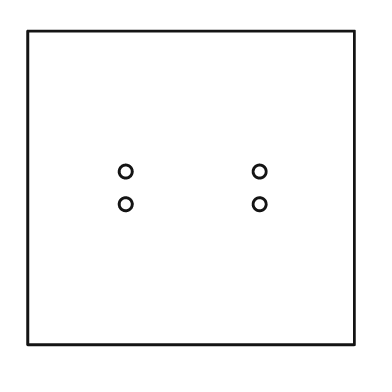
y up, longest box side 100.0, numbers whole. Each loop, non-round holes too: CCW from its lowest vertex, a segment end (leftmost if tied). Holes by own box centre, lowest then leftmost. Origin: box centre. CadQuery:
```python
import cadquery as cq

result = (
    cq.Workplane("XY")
    .moveTo(-50.0, -48.0)
    .lineTo(50.0, -48.0)
    .lineTo(50.0, 48.0)
    .lineTo(-50.0, 48.0)
    .close()
    .moveTo(-20.0, -5.0)
    .circle(2.0)
    .moveTo(21.0, -5.0)
    .circle(2.0)
    .moveTo(-20.0, 5.0)
    .circle(2.0)
    .moveTo(21.0, 5.0)
    .circle(2.0)
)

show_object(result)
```